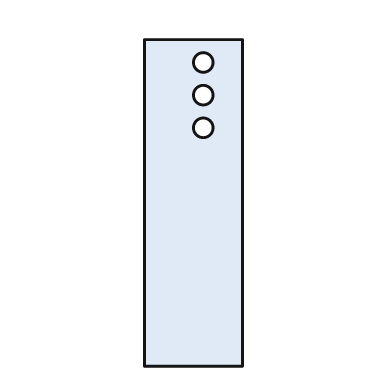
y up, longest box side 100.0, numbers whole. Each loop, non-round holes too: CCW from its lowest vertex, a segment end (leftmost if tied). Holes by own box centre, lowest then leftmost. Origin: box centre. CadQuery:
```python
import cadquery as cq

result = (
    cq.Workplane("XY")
    .moveTo(-15.0, -50.0)
    .lineTo(15.0, -50.0)
    .lineTo(15.0, 50.0)
    .lineTo(-15.0, 50.0)
    .close()
    .moveTo(3.0, 23.0)
    .circle(3.0)
    .moveTo(3.0, 33.0)
    .circle(3.0)
    .moveTo(3.0, 43.0)
    .circle(3.0)
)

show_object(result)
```